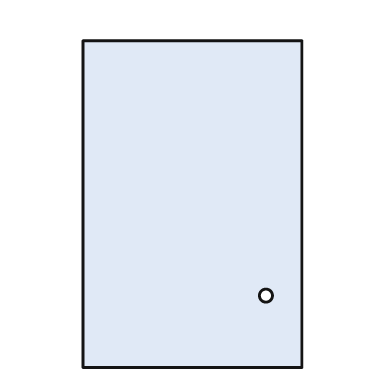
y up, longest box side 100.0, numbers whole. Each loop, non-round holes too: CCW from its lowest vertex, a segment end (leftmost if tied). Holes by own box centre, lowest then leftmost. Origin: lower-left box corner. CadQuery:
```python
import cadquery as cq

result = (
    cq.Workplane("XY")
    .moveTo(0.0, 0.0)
    .lineTo(67.0, 0.0)
    .lineTo(67.0, 100.0)
    .lineTo(0.0, 100.0)
    .close()
    .moveTo(56.0, 22.0)
    .circle(2.0)
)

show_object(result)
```